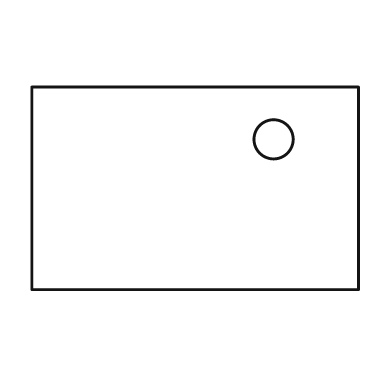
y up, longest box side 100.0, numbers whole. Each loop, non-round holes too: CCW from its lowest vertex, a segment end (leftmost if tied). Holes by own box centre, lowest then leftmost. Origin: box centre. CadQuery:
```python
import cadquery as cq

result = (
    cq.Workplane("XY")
    .moveTo(-50.0, -31.0)
    .lineTo(50.0, -31.0)
    .lineTo(50.0, 31.0)
    .lineTo(-50.0, 31.0)
    .close()
    .moveTo(24.0, 15.0)
    .circle(6.0)
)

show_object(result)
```